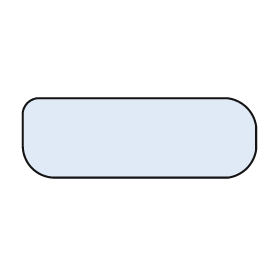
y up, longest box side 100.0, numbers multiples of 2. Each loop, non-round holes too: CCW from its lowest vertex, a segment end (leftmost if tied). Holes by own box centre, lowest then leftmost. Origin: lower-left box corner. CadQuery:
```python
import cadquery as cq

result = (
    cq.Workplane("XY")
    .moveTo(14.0, 0.0)
    .lineTo(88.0, 0.0)
    .threePointArc((96.0, 4.0), (100.0, 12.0))
    .lineTo(100.0, 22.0)
    .threePointArc((96.0, 30.0), (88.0, 34.0))
    .lineTo(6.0, 34.0)
    .threePointArc((2.0, 32.0), (0.0, 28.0))
    .lineTo(0.0, 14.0)
    .threePointArc((4.0, 4.0), (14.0, 0.0))
    .close()
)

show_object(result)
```